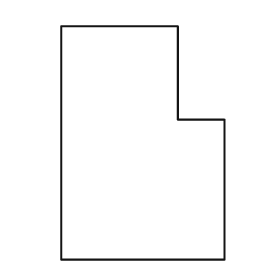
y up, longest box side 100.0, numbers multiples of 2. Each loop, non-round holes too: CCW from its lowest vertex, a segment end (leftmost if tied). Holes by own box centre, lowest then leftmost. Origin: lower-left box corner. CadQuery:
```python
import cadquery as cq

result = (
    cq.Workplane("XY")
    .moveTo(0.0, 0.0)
    .lineTo(70.0, 0.0)
    .lineTo(70.0, 60.0)
    .lineTo(50.0, 60.0)
    .lineTo(50.0, 100.0)
    .lineTo(0.0, 100.0)
    .close()
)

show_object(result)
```